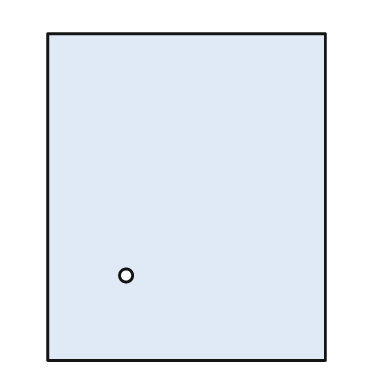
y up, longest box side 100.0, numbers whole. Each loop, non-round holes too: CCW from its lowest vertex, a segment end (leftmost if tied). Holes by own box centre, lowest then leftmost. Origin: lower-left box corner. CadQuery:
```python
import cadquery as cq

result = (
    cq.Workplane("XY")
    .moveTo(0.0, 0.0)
    .lineTo(85.0, 0.0)
    .lineTo(85.0, 100.0)
    .lineTo(0.0, 100.0)
    .close()
    .moveTo(24.0, 26.0)
    .circle(2.0)
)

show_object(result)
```